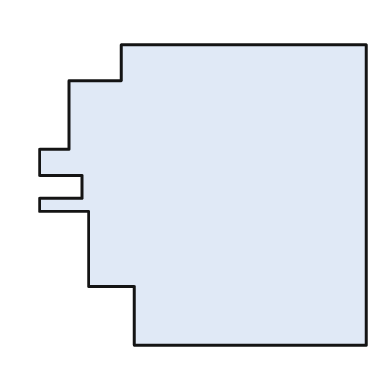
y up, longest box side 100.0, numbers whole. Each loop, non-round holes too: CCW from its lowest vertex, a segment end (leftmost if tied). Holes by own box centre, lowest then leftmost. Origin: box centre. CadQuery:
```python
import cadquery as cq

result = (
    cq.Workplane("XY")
    .moveTo(-21.0, -46.0)
    .lineTo(50.0, -46.0)
    .lineTo(50.0, 46.0)
    .lineTo(-25.0, 46.0)
    .lineTo(-25.0, 35.0)
    .lineTo(-41.0, 35.0)
    .lineTo(-41.0, 14.0)
    .lineTo(-50.0, 14.0)
    .lineTo(-50.0, 6.0)
    .lineTo(-37.0, 6.0)
    .lineTo(-37.0, -1.0)
    .lineTo(-50.0, -1.0)
    .lineTo(-50.0, -5.0)
    .lineTo(-35.0, -5.0)
    .lineTo(-35.0, -28.0)
    .lineTo(-21.0, -28.0)
    .close()
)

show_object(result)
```